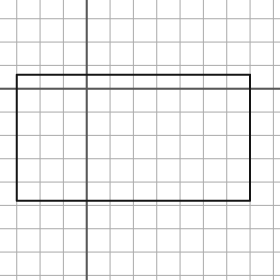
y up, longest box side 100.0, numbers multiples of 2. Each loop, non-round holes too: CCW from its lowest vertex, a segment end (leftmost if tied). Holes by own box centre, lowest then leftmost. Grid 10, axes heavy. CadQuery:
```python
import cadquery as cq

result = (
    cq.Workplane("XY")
    .moveTo(-30.0, -48.0)
    .lineTo(70.0, -48.0)
    .lineTo(70.0, 6.0)
    .lineTo(-30.0, 6.0)
    .close()
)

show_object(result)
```